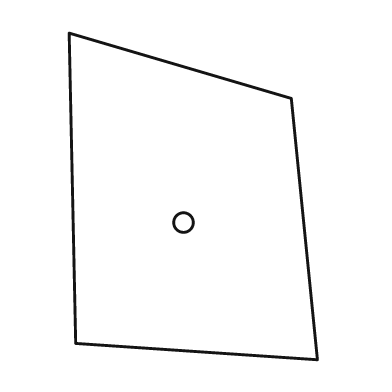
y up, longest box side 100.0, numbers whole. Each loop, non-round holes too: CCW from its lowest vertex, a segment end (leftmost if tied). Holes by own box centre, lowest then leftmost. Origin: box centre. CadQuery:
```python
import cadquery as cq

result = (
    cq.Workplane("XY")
    .moveTo(38.0, -50.0)
    .lineTo(30.0, 30.0)
    .lineTo(-38.0, 50.0)
    .lineTo(-36.0, -45.0)
    .close()
    .moveTo(-3.0, -8.0)
    .circle(3.0)
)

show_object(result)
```